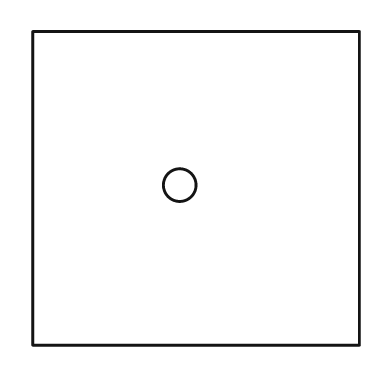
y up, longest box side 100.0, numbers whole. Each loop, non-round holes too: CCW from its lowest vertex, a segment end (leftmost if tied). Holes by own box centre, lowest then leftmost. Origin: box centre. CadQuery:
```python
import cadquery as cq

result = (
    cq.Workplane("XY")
    .moveTo(-50.0, -48.0)
    .lineTo(50.0, -48.0)
    .lineTo(50.0, 48.0)
    .lineTo(-50.0, 48.0)
    .close()
    .moveTo(-5.0, 1.0)
    .circle(5.0)
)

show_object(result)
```